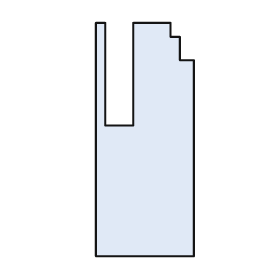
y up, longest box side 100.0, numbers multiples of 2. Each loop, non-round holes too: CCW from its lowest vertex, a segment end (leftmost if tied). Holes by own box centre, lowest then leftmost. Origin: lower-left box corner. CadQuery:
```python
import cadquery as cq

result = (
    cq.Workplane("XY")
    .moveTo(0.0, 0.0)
    .lineTo(42.0, 0.0)
    .lineTo(42.0, 84.0)
    .lineTo(36.0, 84.0)
    .lineTo(36.0, 94.0)
    .lineTo(32.0, 94.0)
    .lineTo(32.0, 100.0)
    .lineTo(16.0, 100.0)
    .lineTo(16.0, 56.0)
    .lineTo(4.0, 56.0)
    .lineTo(4.0, 100.0)
    .lineTo(0.0, 100.0)
    .close()
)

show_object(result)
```